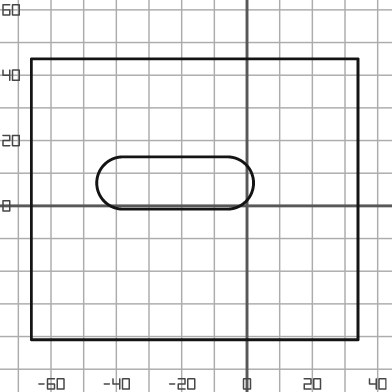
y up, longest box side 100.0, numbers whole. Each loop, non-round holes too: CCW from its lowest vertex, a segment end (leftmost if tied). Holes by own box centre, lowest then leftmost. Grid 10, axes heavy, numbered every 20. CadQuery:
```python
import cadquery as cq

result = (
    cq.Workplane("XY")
    .moveTo(-66.0, -41.0)
    .lineTo(34.0, -41.0)
    .lineTo(34.0, 45.0)
    .lineTo(-66.0, 45.0)
    .close()
    .moveTo(-38.0, -1.0)
    .lineTo(-6.0, -1.0)
    .threePointArc((2.0, 7.0), (-6.0, 15.0))
    .lineTo(-38.0, 15.0)
    .threePointArc((-46.0, 7.0), (-38.0, -1.0))
    .close()
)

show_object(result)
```